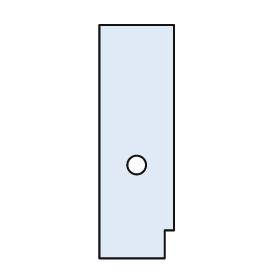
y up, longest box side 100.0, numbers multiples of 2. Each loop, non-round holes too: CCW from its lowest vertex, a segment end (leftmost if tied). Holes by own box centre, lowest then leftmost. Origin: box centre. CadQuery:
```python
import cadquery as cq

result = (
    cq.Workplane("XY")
    .moveTo(-16.0, -50.0)
    .lineTo(12.0, -50.0)
    .lineTo(12.0, -38.0)
    .lineTo(16.0, -38.0)
    .lineTo(16.0, 50.0)
    .lineTo(-16.0, 50.0)
    .close()
    .moveTo(0.0, -10.0)
    .circle(4.0)
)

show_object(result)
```